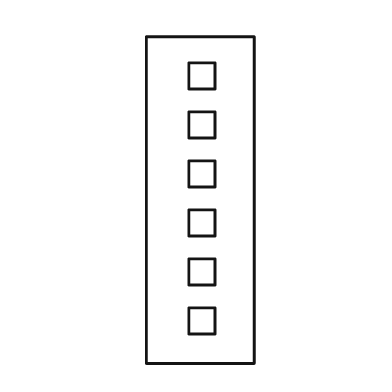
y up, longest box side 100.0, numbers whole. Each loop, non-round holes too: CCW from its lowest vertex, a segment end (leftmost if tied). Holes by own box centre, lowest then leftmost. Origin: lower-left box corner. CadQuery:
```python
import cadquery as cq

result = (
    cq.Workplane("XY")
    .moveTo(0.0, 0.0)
    .lineTo(33.0, 0.0)
    .lineTo(33.0, 100.0)
    .lineTo(0.0, 100.0)
    .close()
    .moveTo(13.0, 9.0)
    .lineTo(21.0, 9.0)
    .lineTo(21.0, 17.0)
    .lineTo(13.0, 17.0)
    .close()
    .moveTo(13.0, 24.0)
    .lineTo(21.0, 24.0)
    .lineTo(21.0, 32.0)
    .lineTo(13.0, 32.0)
    .close()
    .moveTo(13.0, 39.0)
    .lineTo(21.0, 39.0)
    .lineTo(21.0, 47.0)
    .lineTo(13.0, 47.0)
    .close()
    .moveTo(13.0, 54.0)
    .lineTo(21.0, 54.0)
    .lineTo(21.0, 62.0)
    .lineTo(13.0, 62.0)
    .close()
    .moveTo(13.0, 69.0)
    .lineTo(21.0, 69.0)
    .lineTo(21.0, 77.0)
    .lineTo(13.0, 77.0)
    .close()
    .moveTo(13.0, 84.0)
    .lineTo(21.0, 84.0)
    .lineTo(21.0, 92.0)
    .lineTo(13.0, 92.0)
    .close()
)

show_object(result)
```